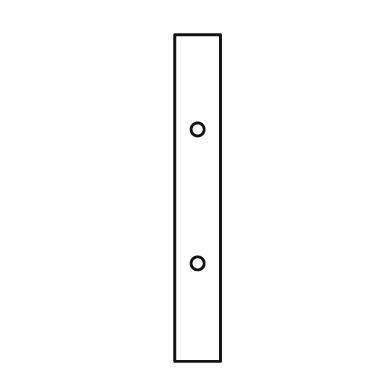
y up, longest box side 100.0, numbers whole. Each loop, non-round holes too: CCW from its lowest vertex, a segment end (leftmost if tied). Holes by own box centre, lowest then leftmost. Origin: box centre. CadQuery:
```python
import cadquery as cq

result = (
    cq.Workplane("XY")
    .moveTo(-7.0, -50.0)
    .lineTo(7.0, -50.0)
    .lineTo(7.0, 50.0)
    .lineTo(-7.0, 50.0)
    .close()
    .moveTo(0.0, -20.0)
    .circle(2.0)
    .moveTo(0.0, 21.0)
    .circle(2.0)
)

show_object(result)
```